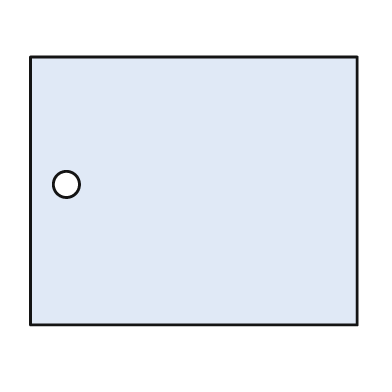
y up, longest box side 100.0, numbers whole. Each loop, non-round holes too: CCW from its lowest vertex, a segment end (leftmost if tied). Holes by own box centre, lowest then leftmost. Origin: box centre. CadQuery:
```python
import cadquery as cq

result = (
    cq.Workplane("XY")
    .moveTo(-50.0, -41.0)
    .lineTo(50.0, -41.0)
    .lineTo(50.0, 41.0)
    .lineTo(-50.0, 41.0)
    .close()
    .moveTo(-39.0, 2.0)
    .circle(4.0)
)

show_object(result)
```